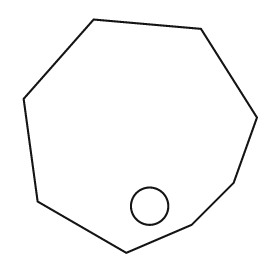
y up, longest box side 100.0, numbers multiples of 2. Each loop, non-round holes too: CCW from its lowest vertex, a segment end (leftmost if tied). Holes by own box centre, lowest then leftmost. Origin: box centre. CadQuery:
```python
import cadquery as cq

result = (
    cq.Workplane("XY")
    .moveTo(-6.0, -50.0)
    .lineTo(22.0, -38.0)
    .lineTo(40.0, -20.0)
    .lineTo(50.0, 8.0)
    .lineTo(26.0, 46.0)
    .lineTo(-20.0, 50.0)
    .lineTo(-50.0, 16.0)
    .lineTo(-44.0, -28.0)
    .close()
    .moveTo(4.0, -30.0)
    .circle(8.0)
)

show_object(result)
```